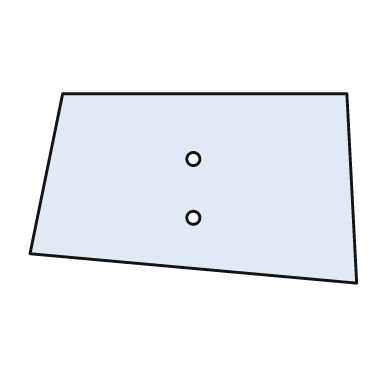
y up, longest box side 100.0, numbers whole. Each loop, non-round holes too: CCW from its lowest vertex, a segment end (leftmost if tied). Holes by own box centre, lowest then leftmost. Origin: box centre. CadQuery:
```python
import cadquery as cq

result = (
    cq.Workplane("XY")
    .moveTo(50.0, -29.0)
    .lineTo(47.0, 29.0)
    .lineTo(-40.0, 29.0)
    .lineTo(-50.0, -20.0)
    .close()
    .moveTo(0.0, -9.0)
    .circle(2.0)
    .moveTo(0.0, 9.0)
    .circle(2.0)
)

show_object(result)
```